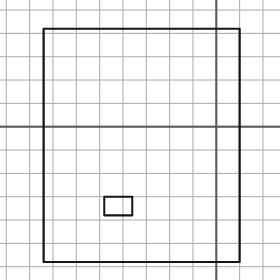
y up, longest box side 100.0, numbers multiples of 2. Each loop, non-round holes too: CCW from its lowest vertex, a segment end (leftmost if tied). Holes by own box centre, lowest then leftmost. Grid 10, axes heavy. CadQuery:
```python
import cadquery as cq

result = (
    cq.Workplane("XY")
    .moveTo(-74.0, -58.0)
    .lineTo(10.0, -58.0)
    .lineTo(10.0, 42.0)
    .lineTo(-74.0, 42.0)
    .close()
    .moveTo(-48.0, -38.0)
    .lineTo(-36.0, -38.0)
    .lineTo(-36.0, -30.0)
    .lineTo(-48.0, -30.0)
    .close()
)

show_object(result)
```